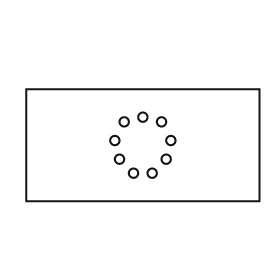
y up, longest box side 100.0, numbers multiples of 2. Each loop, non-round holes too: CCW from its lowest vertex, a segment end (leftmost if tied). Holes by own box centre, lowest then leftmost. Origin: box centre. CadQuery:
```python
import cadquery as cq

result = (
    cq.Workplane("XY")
    .moveTo(-50.0, -24.0)
    .lineTo(50.0, -24.0)
    .lineTo(50.0, 24.0)
    .lineTo(-50.0, 24.0)
    .close()
    .moveTo(-4.0, -12.0)
    .circle(2.0)
    .moveTo(4.0, -12.0)
    .circle(2.0)
    .moveTo(-10.0, -6.0)
    .circle(2.0)
    .moveTo(10.0, -6.0)
    .circle(2.0)
    .moveTo(-12.0, 2.0)
    .circle(2.0)
    .moveTo(12.0, 2.0)
    .circle(2.0)
    .moveTo(-8.0, 10.0)
    .circle(2.0)
    .moveTo(8.0, 10.0)
    .circle(2.0)
    .moveTo(0.0, 12.0)
    .circle(2.0)
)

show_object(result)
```